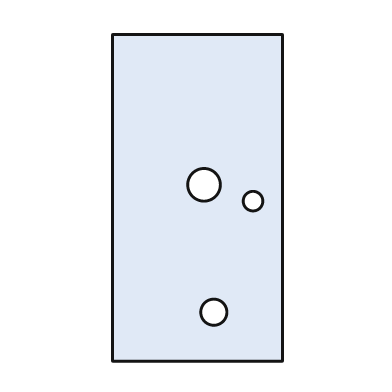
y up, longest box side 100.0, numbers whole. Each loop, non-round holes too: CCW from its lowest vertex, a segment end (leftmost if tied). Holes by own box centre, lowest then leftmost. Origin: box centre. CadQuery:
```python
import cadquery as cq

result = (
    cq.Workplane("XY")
    .moveTo(-26.0, -50.0)
    .lineTo(26.0, -50.0)
    .lineTo(26.0, 50.0)
    .lineTo(-26.0, 50.0)
    .close()
    .moveTo(5.0, -35.0)
    .circle(4.0)
    .moveTo(17.0, -1.0)
    .circle(3.0)
    .moveTo(2.0, 4.0)
    .circle(5.0)
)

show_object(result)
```